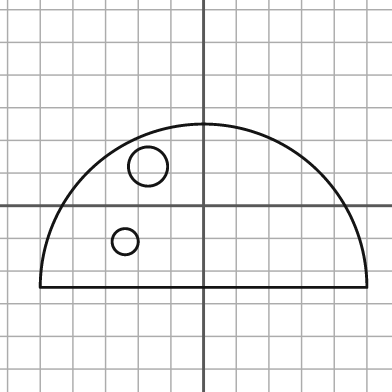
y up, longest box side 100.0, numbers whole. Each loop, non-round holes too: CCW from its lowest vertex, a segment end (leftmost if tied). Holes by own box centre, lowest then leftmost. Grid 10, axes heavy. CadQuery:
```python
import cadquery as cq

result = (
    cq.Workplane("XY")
    .moveTo(-50.0, -25.0)
    .lineTo(50.0, -25.0)
    .threePointArc((0.0, 25.0), (-50.0, -25.0))
    .close()
    .moveTo(-24.0, -11.0)
    .circle(4.0)
    .moveTo(-17.0, 12.0)
    .circle(6.0)
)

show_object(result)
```